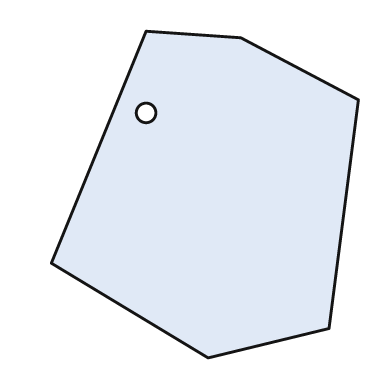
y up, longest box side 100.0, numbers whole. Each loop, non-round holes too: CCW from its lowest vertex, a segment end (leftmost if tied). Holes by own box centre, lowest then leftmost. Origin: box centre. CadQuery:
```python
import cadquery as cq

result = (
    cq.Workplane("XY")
    .moveTo(1.0, -50.0)
    .lineTo(38.0, -41.0)
    .lineTo(47.0, 29.0)
    .lineTo(11.0, 48.0)
    .lineTo(-18.0, 50.0)
    .lineTo(-47.0, -21.0)
    .close()
    .moveTo(-18.0, 25.0)
    .circle(3.0)
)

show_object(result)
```